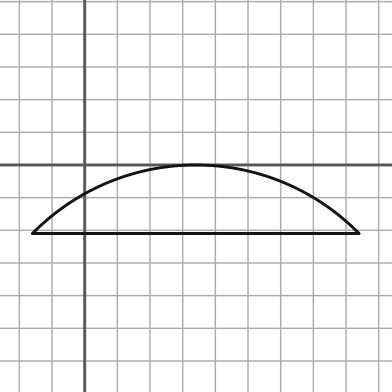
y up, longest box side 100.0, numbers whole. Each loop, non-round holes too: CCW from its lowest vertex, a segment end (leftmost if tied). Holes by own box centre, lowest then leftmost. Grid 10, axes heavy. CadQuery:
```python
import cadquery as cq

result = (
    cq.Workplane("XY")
    .moveTo(-16.0, -21.0)
    .lineTo(84.0, -21.0)
    .threePointArc((34.0, 0.0), (-16.0, -21.0))
    .close()
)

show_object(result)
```